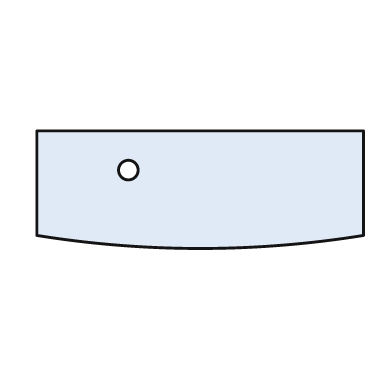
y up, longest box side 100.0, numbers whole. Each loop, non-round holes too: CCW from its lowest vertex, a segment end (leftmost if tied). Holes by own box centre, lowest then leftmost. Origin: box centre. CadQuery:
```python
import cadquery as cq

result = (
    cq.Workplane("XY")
    .moveTo(-50.0, -14.0)
    .threePointArc((0.0, -18.0), (50.0, -14.0))
    .lineTo(50.0, 18.0)
    .lineTo(-50.0, 18.0)
    .close()
    .moveTo(-22.0, 6.0)
    .circle(3.0)
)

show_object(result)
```